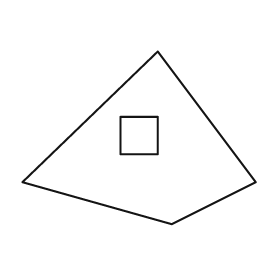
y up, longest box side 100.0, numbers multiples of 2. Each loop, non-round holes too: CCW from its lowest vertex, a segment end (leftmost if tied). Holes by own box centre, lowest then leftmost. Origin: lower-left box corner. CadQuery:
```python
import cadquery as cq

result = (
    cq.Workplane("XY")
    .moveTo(64.0, 0.0)
    .lineTo(100.0, 18.0)
    .lineTo(58.0, 74.0)
    .lineTo(0.0, 18.0)
    .close()
    .moveTo(42.0, 30.0)
    .lineTo(58.0, 30.0)
    .lineTo(58.0, 46.0)
    .lineTo(42.0, 46.0)
    .close()
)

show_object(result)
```